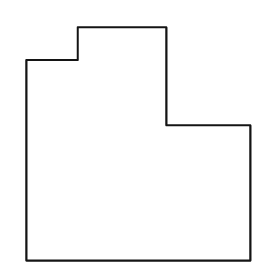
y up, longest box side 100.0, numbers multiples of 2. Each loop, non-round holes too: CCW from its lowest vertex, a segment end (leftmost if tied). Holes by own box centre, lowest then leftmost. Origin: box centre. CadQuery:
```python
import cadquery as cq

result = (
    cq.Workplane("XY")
    .moveTo(-48.0, -50.0)
    .lineTo(48.0, -50.0)
    .lineTo(48.0, 8.0)
    .lineTo(12.0, 8.0)
    .lineTo(12.0, 50.0)
    .lineTo(-26.0, 50.0)
    .lineTo(-26.0, 36.0)
    .lineTo(-48.0, 36.0)
    .close()
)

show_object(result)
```